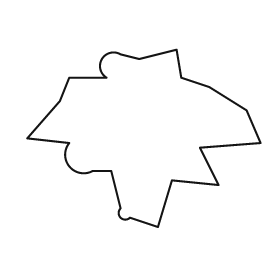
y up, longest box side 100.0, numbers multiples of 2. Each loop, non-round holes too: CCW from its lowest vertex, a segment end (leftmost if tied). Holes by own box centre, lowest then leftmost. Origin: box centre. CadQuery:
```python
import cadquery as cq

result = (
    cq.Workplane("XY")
    .moveTo(6.0, -38.0)
    .lineTo(12.0, -18.0)
    .lineTo(32.0, -20.0)
    .lineTo(24.0, -4.0)
    .lineTo(50.0, -2.0)
    .lineTo(44.0, 12.0)
    .lineTo(28.0, 22.0)
    .lineTo(16.0, 26.0)
    .lineTo(14.0, 38.0)
    .lineTo(-2.0, 34.0)
    .lineTo(-10.0, 36.0)
    .threePointArc((-18.0, 34.0), (-16.0, 26.0))
    .lineTo(-32.0, 26.0)
    .lineTo(-36.0, 16.0)
    .lineTo(-50.0, 0.0)
    .lineTo(-32.0, -2.0)
    .threePointArc((-32.0, -12.0), (-22.0, -14.0))
    .lineTo(-14.0, -14.0)
    .lineTo(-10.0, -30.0)
    .threePointArc((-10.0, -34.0), (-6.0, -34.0))
    .close()
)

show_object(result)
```